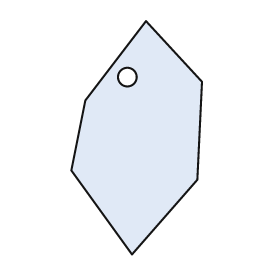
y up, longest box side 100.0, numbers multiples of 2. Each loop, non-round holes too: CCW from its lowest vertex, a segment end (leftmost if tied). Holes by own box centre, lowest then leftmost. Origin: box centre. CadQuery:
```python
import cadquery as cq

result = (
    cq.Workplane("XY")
    .moveTo(-2.0, -50.0)
    .lineTo(26.0, -18.0)
    .lineTo(28.0, 24.0)
    .lineTo(4.0, 50.0)
    .lineTo(-22.0, 16.0)
    .lineTo(-28.0, -14.0)
    .close()
    .moveTo(-4.0, 26.0)
    .circle(4.0)
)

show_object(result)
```